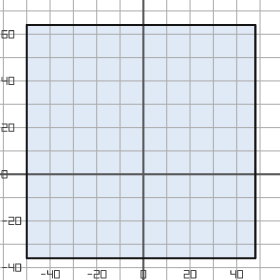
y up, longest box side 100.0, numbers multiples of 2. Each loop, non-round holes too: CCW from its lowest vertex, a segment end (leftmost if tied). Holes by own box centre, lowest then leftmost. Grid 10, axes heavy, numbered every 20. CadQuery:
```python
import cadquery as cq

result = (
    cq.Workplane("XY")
    .moveTo(-50.0, -36.0)
    .lineTo(48.0, -36.0)
    .lineTo(48.0, 64.0)
    .lineTo(-50.0, 64.0)
    .close()
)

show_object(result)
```